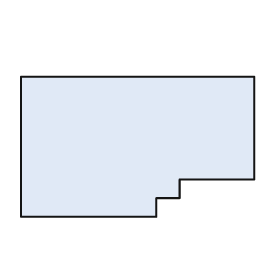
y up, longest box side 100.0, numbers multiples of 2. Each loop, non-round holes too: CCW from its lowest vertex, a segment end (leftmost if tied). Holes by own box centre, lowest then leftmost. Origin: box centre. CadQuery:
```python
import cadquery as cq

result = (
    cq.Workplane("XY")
    .moveTo(-50.0, -30.0)
    .lineTo(8.0, -30.0)
    .lineTo(8.0, -22.0)
    .lineTo(18.0, -22.0)
    .lineTo(18.0, -14.0)
    .lineTo(50.0, -14.0)
    .lineTo(50.0, 30.0)
    .lineTo(-50.0, 30.0)
    .close()
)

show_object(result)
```